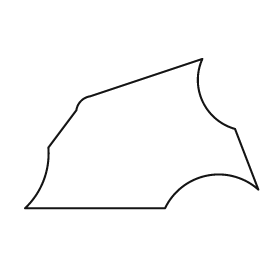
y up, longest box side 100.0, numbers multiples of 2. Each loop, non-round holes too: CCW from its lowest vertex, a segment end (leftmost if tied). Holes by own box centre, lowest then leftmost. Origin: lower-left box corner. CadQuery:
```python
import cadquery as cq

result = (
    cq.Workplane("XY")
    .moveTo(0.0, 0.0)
    .lineTo(60.0, 0.0)
    .threePointArc((78.0, 14.0), (100.0, 8.0))
    .lineTo(90.0, 34.0)
    .threePointArc((76.0, 46.0), (76.0, 64.0))
    .lineTo(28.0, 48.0)
    .threePointArc((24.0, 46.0), (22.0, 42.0))
    .lineTo(10.0, 26.0)
    .threePointArc((8.0, 12.0), (0.0, 0.0))
    .close()
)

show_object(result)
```